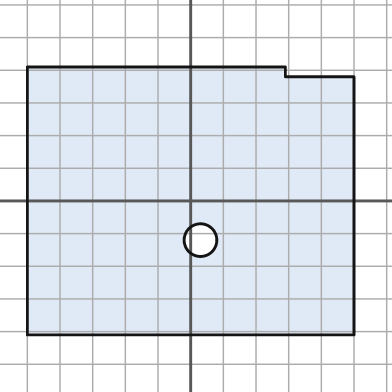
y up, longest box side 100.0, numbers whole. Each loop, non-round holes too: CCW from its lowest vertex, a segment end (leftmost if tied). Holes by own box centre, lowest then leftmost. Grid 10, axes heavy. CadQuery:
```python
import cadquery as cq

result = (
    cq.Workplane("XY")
    .moveTo(-50.0, -41.0)
    .lineTo(50.0, -41.0)
    .lineTo(50.0, 38.0)
    .lineTo(29.0, 38.0)
    .lineTo(29.0, 41.0)
    .lineTo(-50.0, 41.0)
    .close()
    .moveTo(3.0, -12.0)
    .circle(5.0)
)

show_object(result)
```